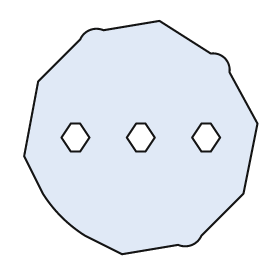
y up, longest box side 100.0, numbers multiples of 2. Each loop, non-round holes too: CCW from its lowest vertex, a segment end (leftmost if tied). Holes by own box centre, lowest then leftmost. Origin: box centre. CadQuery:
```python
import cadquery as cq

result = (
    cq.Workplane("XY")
    .moveTo(-8.0, -50.0)
    .lineTo(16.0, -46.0)
    .threePointArc((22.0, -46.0), (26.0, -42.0))
    .lineTo(44.0, -24.0)
    .lineTo(50.0, 6.0)
    .lineTo(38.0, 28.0)
    .threePointArc((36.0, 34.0), (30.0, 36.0))
    .lineTo(8.0, 50.0)
    .lineTo(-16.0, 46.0)
    .threePointArc((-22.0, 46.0), (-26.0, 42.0))
    .lineTo(-44.0, 24.0)
    .lineTo(-50.0, -8.0)
    .lineTo(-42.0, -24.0)
    .threePointArc((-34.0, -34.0), (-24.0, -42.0))
    .close()
    .moveTo(-30.0, -6.0)
    .lineTo(-26.0, -6.0)
    .lineTo(-22.0, 0.0)
    .lineTo(-26.0, 6.0)
    .lineTo(-30.0, 6.0)
    .lineTo(-34.0, 0.0)
    .close()
    .moveTo(-2.0, -6.0)
    .lineTo(2.0, -6.0)
    .lineTo(6.0, 0.0)
    .lineTo(2.0, 6.0)
    .lineTo(-2.0, 6.0)
    .lineTo(-6.0, 0.0)
    .close()
    .moveTo(26.0, -6.0)
    .lineTo(30.0, -6.0)
    .lineTo(34.0, 0.0)
    .lineTo(30.0, 6.0)
    .lineTo(26.0, 6.0)
    .lineTo(22.0, 0.0)
    .close()
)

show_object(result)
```